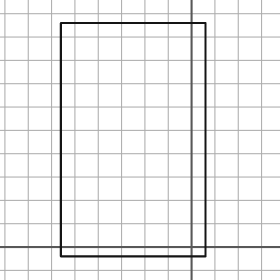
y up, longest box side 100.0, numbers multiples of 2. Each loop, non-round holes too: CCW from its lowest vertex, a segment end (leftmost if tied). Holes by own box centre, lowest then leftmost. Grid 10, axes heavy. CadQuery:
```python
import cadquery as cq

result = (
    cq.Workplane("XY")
    .moveTo(-56.0, -4.0)
    .lineTo(6.0, -4.0)
    .lineTo(6.0, 96.0)
    .lineTo(-56.0, 96.0)
    .close()
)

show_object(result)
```